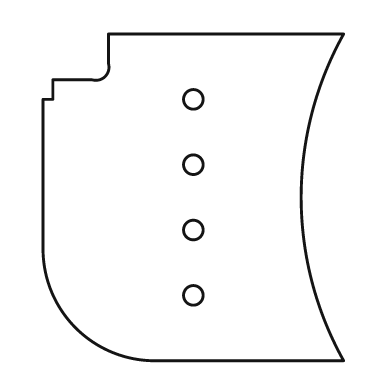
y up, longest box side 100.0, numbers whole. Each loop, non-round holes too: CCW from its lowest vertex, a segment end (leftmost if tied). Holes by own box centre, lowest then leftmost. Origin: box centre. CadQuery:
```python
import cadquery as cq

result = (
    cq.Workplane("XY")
    .moveTo(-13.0, -50.0)
    .lineTo(46.0, -50.0)
    .threePointArc((33.0, 0.0), (46.0, 50.0))
    .lineTo(-26.0, 50.0)
    .lineTo(-26.0, 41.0)
    .threePointArc((-27.0, 37.0), (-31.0, 36.0))
    .lineTo(-43.0, 36.0)
    .lineTo(-43.0, 30.0)
    .lineTo(-46.0, 30.0)
    .lineTo(-46.0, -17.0)
    .threePointArc((-36.0, -40.0), (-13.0, -50.0))
    .close()
    .moveTo(0.0, -30.0)
    .circle(3.0)
    .moveTo(0.0, -10.0)
    .circle(3.0)
    .moveTo(0.0, 10.0)
    .circle(3.0)
    .moveTo(0.0, 30.0)
    .circle(3.0)
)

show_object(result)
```